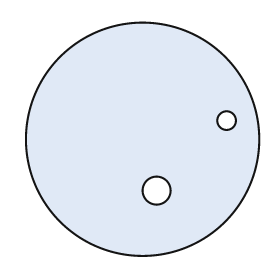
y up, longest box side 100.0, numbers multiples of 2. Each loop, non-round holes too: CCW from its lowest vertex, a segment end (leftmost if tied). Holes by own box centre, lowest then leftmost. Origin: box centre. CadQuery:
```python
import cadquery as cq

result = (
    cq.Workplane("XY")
    .moveTo(0.0, 0.0)
    .circle(50.0)
    .moveTo(6.0, -22.0)
    .circle(6.0)
    .moveTo(36.0, 8.0)
    .circle(4.0)
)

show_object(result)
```